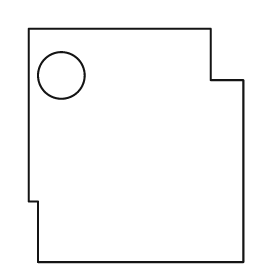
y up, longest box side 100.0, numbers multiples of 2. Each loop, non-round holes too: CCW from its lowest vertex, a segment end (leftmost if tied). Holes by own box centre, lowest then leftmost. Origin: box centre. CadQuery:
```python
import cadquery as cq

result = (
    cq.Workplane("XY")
    .moveTo(-42.0, -50.0)
    .lineTo(46.0, -50.0)
    .lineTo(46.0, 28.0)
    .lineTo(32.0, 28.0)
    .lineTo(32.0, 50.0)
    .lineTo(-46.0, 50.0)
    .lineTo(-46.0, -24.0)
    .lineTo(-42.0, -24.0)
    .close()
    .moveTo(-32.0, 30.0)
    .circle(10.0)
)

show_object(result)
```